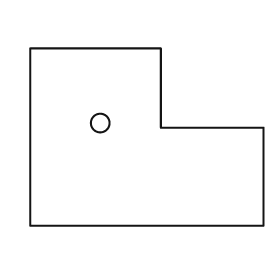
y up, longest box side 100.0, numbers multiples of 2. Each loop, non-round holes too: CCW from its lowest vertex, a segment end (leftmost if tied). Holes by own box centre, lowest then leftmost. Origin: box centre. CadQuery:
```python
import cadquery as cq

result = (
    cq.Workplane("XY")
    .moveTo(-50.0, -38.0)
    .lineTo(50.0, -38.0)
    .lineTo(50.0, 4.0)
    .lineTo(6.0, 4.0)
    .lineTo(6.0, 38.0)
    .lineTo(-50.0, 38.0)
    .close()
    .moveTo(-20.0, 6.0)
    .circle(4.0)
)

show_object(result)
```